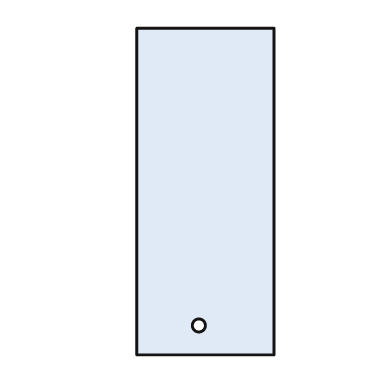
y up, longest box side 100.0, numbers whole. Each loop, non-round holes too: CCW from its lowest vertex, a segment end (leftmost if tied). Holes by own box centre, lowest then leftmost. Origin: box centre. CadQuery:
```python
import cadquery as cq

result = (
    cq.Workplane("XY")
    .moveTo(-21.0, -50.0)
    .lineTo(21.0, -50.0)
    .lineTo(21.0, 50.0)
    .lineTo(-21.0, 50.0)
    .close()
    .moveTo(-2.0, -41.0)
    .circle(2.0)
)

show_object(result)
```